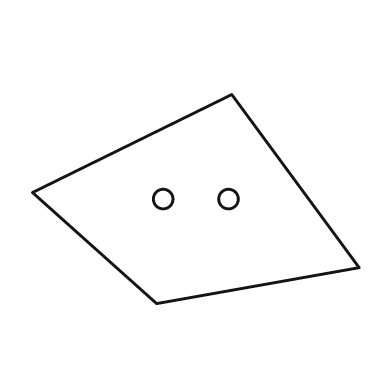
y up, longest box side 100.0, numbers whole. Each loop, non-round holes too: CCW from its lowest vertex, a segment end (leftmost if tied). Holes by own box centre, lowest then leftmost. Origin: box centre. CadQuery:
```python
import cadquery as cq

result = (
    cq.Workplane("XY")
    .moveTo(-12.0, -32.0)
    .lineTo(50.0, -21.0)
    .lineTo(11.0, 32.0)
    .lineTo(-50.0, 2.0)
    .close()
    .moveTo(-10.0, 0.0)
    .circle(3.0)
    .moveTo(10.0, 0.0)
    .circle(3.0)
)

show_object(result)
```